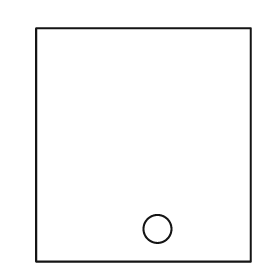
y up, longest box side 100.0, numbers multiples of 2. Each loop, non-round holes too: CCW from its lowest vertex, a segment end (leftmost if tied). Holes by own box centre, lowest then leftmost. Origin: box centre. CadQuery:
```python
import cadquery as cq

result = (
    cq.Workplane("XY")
    .moveTo(-46.0, -50.0)
    .lineTo(46.0, -50.0)
    .lineTo(46.0, 50.0)
    .lineTo(-46.0, 50.0)
    .close()
    .moveTo(6.0, -36.0)
    .circle(6.0)
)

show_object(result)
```